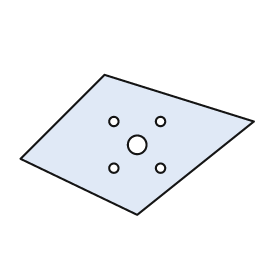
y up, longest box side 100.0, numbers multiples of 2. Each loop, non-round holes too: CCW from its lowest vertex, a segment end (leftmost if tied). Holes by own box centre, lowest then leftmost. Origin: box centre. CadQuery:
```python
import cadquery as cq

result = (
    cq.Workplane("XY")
    .moveTo(0.0, -30.0)
    .lineTo(50.0, 10.0)
    .lineTo(-14.0, 30.0)
    .lineTo(-50.0, -6.0)
    .close()
    .moveTo(-10.0, -10.0)
    .circle(2.0)
    .moveTo(10.0, -10.0)
    .circle(2.0)
    .moveTo(0.0, 0.0)
    .circle(4.0)
    .moveTo(-10.0, 10.0)
    .circle(2.0)
    .moveTo(10.0, 10.0)
    .circle(2.0)
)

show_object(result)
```